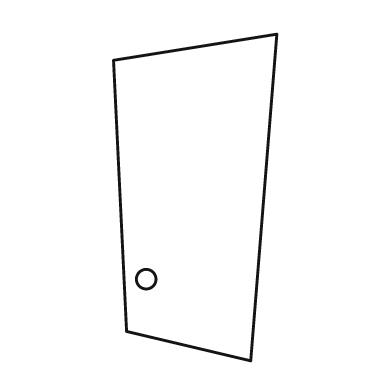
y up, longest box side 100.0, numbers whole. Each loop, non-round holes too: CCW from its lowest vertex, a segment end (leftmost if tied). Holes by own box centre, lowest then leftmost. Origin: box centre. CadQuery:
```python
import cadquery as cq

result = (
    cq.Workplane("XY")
    .moveTo(17.0, -50.0)
    .lineTo(25.0, 50.0)
    .lineTo(-25.0, 42.0)
    .lineTo(-21.0, -41.0)
    .close()
    .moveTo(-15.0, -25.0)
    .circle(3.0)
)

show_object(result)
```